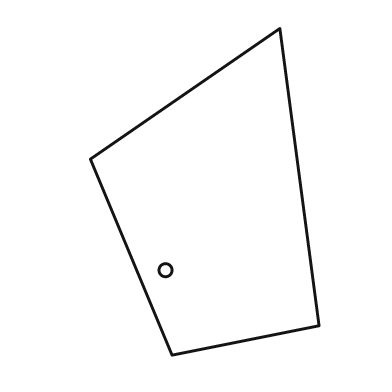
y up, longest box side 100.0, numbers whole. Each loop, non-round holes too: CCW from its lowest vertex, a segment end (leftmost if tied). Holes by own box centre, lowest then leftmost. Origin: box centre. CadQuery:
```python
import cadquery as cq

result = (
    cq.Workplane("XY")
    .moveTo(-10.0, -50.0)
    .lineTo(35.0, -41.0)
    .lineTo(23.0, 50.0)
    .lineTo(-35.0, 10.0)
    .close()
    .moveTo(-12.0, -24.0)
    .circle(2.0)
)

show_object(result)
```